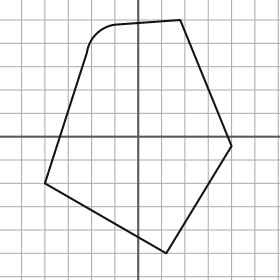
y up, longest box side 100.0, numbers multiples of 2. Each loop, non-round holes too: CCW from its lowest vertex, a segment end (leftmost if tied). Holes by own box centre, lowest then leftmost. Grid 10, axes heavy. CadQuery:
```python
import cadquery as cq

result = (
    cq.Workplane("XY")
    .moveTo(12.0, -50.0)
    .lineTo(40.0, -4.0)
    .lineTo(18.0, 50.0)
    .lineTo(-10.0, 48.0)
    .threePointArc((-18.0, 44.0), (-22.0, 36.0))
    .lineTo(-40.0, -20.0)
    .close()
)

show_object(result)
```